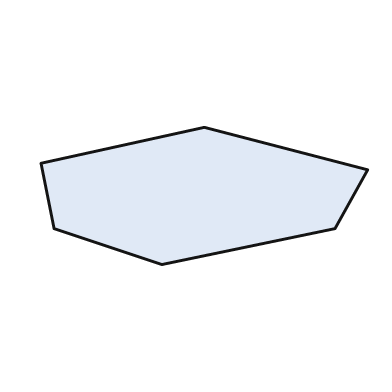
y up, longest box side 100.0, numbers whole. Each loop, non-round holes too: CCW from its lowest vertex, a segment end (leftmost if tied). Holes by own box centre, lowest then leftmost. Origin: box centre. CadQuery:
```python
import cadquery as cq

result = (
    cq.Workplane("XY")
    .moveTo(-13.0, -21.0)
    .lineTo(40.0, -10.0)
    .lineTo(50.0, 8.0)
    .lineTo(0.0, 21.0)
    .lineTo(-50.0, 10.0)
    .lineTo(-46.0, -10.0)
    .close()
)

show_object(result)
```